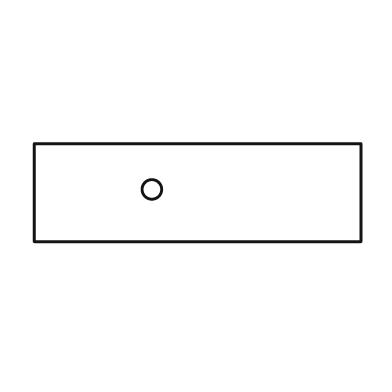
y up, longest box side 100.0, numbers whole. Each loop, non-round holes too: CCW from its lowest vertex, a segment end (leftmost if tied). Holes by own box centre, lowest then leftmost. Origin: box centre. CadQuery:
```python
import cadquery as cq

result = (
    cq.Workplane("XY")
    .moveTo(-50.0, -15.0)
    .lineTo(50.0, -15.0)
    .lineTo(50.0, 15.0)
    .lineTo(-50.0, 15.0)
    .close()
    .moveTo(-14.0, 1.0)
    .circle(3.0)
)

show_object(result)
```